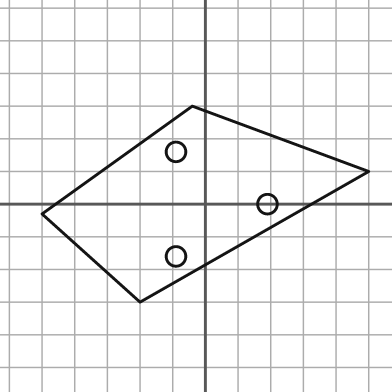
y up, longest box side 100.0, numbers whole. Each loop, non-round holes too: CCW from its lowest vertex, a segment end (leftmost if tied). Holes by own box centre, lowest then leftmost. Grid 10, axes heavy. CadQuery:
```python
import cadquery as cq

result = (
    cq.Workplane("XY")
    .moveTo(-20.0, -30.0)
    .lineTo(50.0, 10.0)
    .lineTo(-4.0, 30.0)
    .lineTo(-50.0, -3.0)
    .close()
    .moveTo(-9.0, -16.0)
    .circle(3.0)
    .moveTo(19.0, 0.0)
    .circle(3.0)
    .moveTo(-9.0, 16.0)
    .circle(3.0)
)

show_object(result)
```